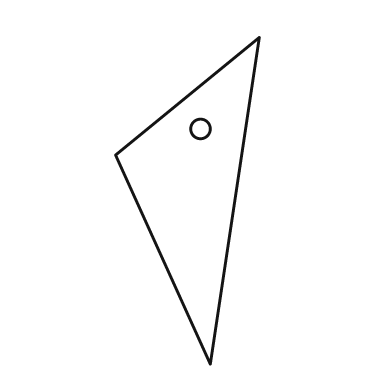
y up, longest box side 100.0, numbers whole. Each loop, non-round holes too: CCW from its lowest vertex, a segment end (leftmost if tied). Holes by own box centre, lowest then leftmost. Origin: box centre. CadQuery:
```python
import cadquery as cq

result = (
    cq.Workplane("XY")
    .moveTo(7.0, -50.0)
    .lineTo(22.0, 50.0)
    .lineTo(-22.0, 14.0)
    .close()
    .moveTo(4.0, 22.0)
    .circle(3.0)
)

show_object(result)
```